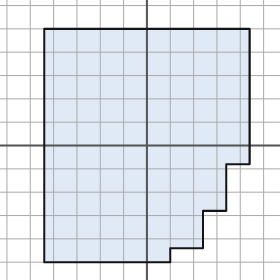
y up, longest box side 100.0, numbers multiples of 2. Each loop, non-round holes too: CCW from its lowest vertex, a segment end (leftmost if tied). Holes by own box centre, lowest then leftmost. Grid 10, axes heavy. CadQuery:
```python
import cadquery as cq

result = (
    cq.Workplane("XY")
    .moveTo(-44.0, -50.0)
    .lineTo(10.0, -50.0)
    .lineTo(10.0, -44.0)
    .lineTo(24.0, -44.0)
    .lineTo(24.0, -28.0)
    .lineTo(34.0, -28.0)
    .lineTo(34.0, -8.0)
    .lineTo(44.0, -8.0)
    .lineTo(44.0, 50.0)
    .lineTo(-44.0, 50.0)
    .close()
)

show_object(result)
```